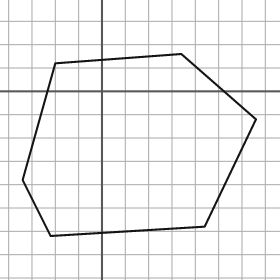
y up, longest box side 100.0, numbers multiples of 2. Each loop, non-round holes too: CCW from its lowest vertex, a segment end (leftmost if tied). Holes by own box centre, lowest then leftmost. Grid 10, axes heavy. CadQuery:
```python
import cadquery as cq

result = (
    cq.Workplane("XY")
    .moveTo(-22.0, -62.0)
    .lineTo(44.0, -58.0)
    .lineTo(66.0, -12.0)
    .lineTo(34.0, 16.0)
    .lineTo(-20.0, 12.0)
    .lineTo(-34.0, -38.0)
    .close()
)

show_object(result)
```